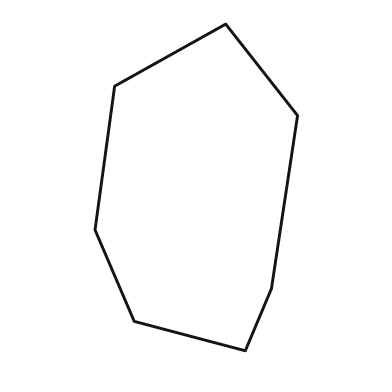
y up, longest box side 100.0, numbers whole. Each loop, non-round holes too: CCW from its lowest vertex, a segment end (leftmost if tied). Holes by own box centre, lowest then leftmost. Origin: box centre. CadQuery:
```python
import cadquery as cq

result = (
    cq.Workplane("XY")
    .moveTo(15.0, -50.0)
    .lineTo(23.0, -31.0)
    .lineTo(31.0, 22.0)
    .lineTo(9.0, 50.0)
    .lineTo(-25.0, 31.0)
    .lineTo(-31.0, -13.0)
    .lineTo(-19.0, -41.0)
    .close()
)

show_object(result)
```